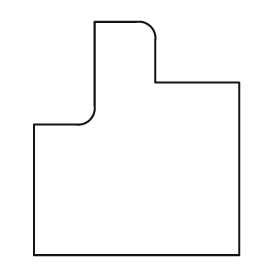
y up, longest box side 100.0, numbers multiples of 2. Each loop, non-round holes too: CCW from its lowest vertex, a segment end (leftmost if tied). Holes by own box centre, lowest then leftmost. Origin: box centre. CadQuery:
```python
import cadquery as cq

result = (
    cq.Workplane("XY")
    .moveTo(-44.0, -50.0)
    .lineTo(44.0, -50.0)
    .lineTo(44.0, 24.0)
    .lineTo(8.0, 24.0)
    .lineTo(8.0, 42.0)
    .threePointArc((6.0, 48.0), (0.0, 50.0))
    .lineTo(-18.0, 50.0)
    .lineTo(-18.0, 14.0)
    .threePointArc((-20.0, 8.0), (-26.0, 6.0))
    .lineTo(-44.0, 6.0)
    .close()
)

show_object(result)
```